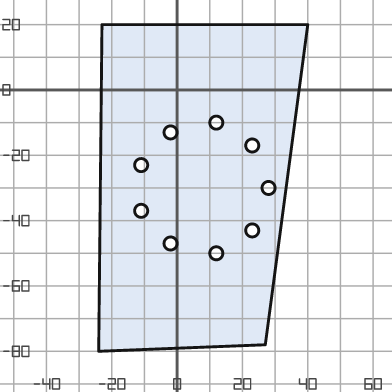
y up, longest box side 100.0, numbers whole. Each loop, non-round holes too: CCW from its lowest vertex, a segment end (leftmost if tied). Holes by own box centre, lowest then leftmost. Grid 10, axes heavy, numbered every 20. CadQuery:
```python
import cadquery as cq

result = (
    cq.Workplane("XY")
    .moveTo(-24.0, -80.0)
    .lineTo(27.0, -78.0)
    .lineTo(40.0, 20.0)
    .lineTo(-23.0, 20.0)
    .close()
    .moveTo(12.0, -50.0)
    .circle(2.0)
    .moveTo(-2.0, -47.0)
    .circle(2.0)
    .moveTo(23.0, -43.0)
    .circle(2.0)
    .moveTo(-11.0, -37.0)
    .circle(2.0)
    .moveTo(28.0, -30.0)
    .circle(2.0)
    .moveTo(-11.0, -23.0)
    .circle(2.0)
    .moveTo(23.0, -17.0)
    .circle(2.0)
    .moveTo(-2.0, -13.0)
    .circle(2.0)
    .moveTo(12.0, -10.0)
    .circle(2.0)
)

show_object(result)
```